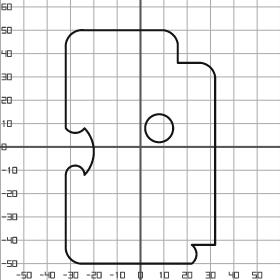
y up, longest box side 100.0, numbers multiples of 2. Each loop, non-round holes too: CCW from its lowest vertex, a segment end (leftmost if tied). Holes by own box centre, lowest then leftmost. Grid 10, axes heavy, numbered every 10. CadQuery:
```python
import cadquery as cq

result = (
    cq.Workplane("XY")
    .moveTo(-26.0, -50.0)
    .lineTo(22.0, -50.0)
    .threePointArc((24.0, -46.0), (22.0, -42.0))
    .lineTo(32.0, -42.0)
    .lineTo(32.0, 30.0)
    .threePointArc((30.0, 34.0), (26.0, 36.0))
    .lineTo(16.0, 36.0)
    .lineTo(16.0, 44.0)
    .threePointArc((14.0, 48.0), (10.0, 50.0))
    .lineTo(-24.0, 50.0)
    .threePointArc((-30.0, 48.0), (-32.0, 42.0))
    .lineTo(-32.0, 8.0)
    .threePointArc((-28.0, 6.0), (-24.0, 8.0))
    .threePointArc((-20.0, -2.0), (-24.0, -12.0))
    .threePointArc((-28.0, -8.0), (-32.0, -12.0))
    .lineTo(-32.0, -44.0)
    .threePointArc((-30.0, -48.0), (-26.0, -50.0))
    .close()
    .moveTo(8.0, 8.0)
    .circle(6.0)
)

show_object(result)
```